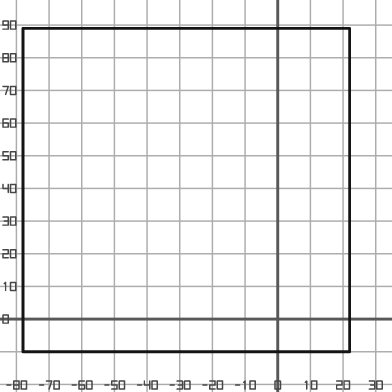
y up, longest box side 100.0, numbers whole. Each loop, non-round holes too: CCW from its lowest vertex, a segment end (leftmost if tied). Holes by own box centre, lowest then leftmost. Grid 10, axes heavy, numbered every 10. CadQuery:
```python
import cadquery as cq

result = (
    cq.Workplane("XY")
    .moveTo(-78.0, -10.0)
    .lineTo(22.0, -10.0)
    .lineTo(22.0, 89.0)
    .lineTo(-78.0, 89.0)
    .close()
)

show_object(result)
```